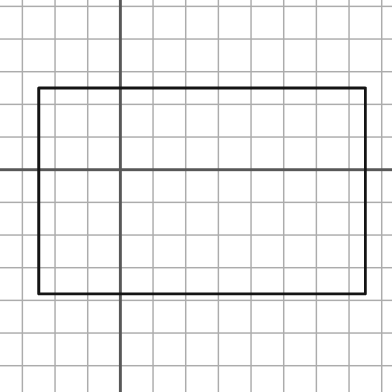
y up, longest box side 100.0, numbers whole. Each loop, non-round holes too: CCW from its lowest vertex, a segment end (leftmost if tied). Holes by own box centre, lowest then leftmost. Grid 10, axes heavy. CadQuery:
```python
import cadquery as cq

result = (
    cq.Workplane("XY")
    .moveTo(-25.0, -38.0)
    .lineTo(75.0, -38.0)
    .lineTo(75.0, 25.0)
    .lineTo(-25.0, 25.0)
    .close()
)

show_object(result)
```